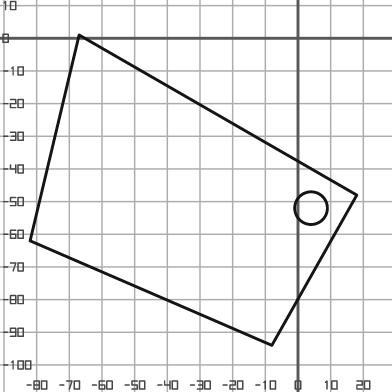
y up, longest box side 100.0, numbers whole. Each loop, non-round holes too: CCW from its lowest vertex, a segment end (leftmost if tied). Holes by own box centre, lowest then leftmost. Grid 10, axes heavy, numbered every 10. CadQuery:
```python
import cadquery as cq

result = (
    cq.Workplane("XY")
    .moveTo(-8.0, -94.0)
    .lineTo(18.0, -48.0)
    .lineTo(-67.0, 1.0)
    .lineTo(-82.0, -62.0)
    .close()
    .moveTo(4.0, -52.0)
    .circle(5.0)
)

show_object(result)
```